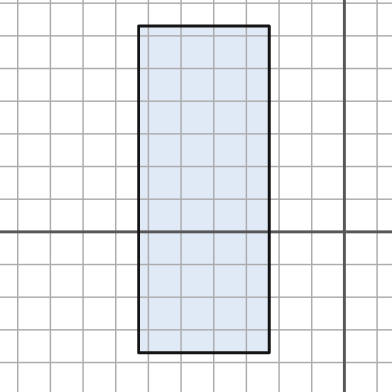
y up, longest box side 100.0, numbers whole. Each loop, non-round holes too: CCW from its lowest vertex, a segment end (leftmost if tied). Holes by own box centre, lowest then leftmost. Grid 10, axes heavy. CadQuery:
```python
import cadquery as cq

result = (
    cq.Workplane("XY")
    .moveTo(-63.0, -37.0)
    .lineTo(-23.0, -37.0)
    .lineTo(-23.0, 63.0)
    .lineTo(-63.0, 63.0)
    .close()
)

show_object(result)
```